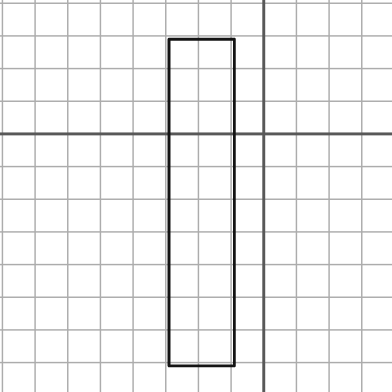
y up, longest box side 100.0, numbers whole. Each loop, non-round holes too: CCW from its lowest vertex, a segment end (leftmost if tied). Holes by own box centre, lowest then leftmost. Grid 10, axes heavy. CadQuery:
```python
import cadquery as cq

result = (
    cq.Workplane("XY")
    .moveTo(-29.0, -71.0)
    .lineTo(-9.0, -71.0)
    .lineTo(-9.0, 29.0)
    .lineTo(-29.0, 29.0)
    .close()
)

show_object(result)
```